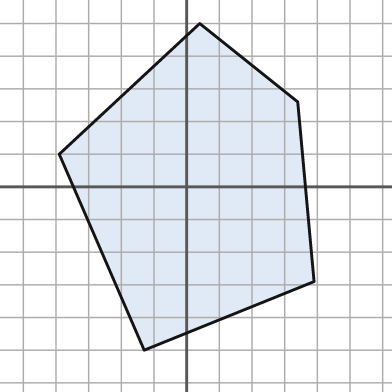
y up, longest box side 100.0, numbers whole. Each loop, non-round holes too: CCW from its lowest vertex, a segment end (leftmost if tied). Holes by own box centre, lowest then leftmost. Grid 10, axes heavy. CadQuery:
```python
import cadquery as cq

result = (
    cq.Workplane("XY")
    .moveTo(-13.0, -50.0)
    .lineTo(39.0, -29.0)
    .lineTo(34.0, 26.0)
    .lineTo(4.0, 50.0)
    .lineTo(-39.0, 10.0)
    .close()
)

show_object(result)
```